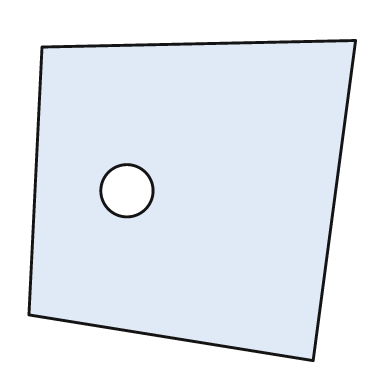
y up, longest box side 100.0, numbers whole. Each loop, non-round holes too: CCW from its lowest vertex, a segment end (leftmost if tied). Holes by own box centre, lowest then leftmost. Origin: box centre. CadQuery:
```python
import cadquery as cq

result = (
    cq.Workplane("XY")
    .moveTo(37.0, -49.0)
    .lineTo(50.0, 49.0)
    .lineTo(-46.0, 47.0)
    .lineTo(-50.0, -35.0)
    .close()
    .moveTo(-20.0, 3.0)
    .circle(8.0)
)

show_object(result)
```